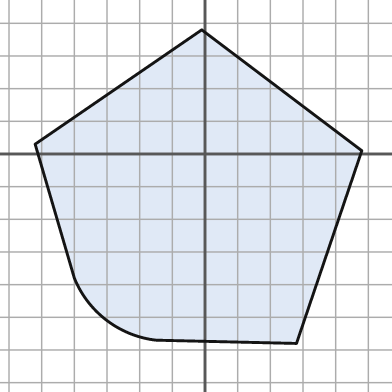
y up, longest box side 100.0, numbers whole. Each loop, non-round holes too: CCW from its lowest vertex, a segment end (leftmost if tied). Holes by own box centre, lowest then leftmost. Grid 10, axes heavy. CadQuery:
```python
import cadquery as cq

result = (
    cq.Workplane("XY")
    .moveTo(28.0, -58.0)
    .lineTo(48.0, 1.0)
    .lineTo(-1.0, 38.0)
    .lineTo(-52.0, 3.0)
    .lineTo(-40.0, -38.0)
    .threePointArc((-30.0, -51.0), (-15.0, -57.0))
    .close()
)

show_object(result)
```